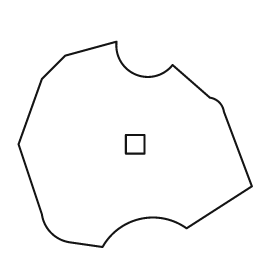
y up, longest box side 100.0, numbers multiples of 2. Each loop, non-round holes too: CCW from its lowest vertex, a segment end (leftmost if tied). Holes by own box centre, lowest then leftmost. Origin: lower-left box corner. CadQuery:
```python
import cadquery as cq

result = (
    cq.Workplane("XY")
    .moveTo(36.0, 0.0)
    .threePointArc((52.0, 12.0), (72.0, 8.0))
    .lineTo(100.0, 26.0)
    .lineTo(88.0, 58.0)
    .threePointArc((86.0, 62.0), (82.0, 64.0))
    .lineTo(66.0, 78.0)
    .threePointArc((50.0, 74.0), (42.0, 88.0))
    .lineTo(20.0, 82.0)
    .lineTo(10.0, 72.0)
    .lineTo(0.0, 44.0)
    .lineTo(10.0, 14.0)
    .threePointArc((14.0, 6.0), (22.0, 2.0))
    .close()
    .moveTo(46.0, 40.0)
    .lineTo(54.0, 40.0)
    .lineTo(54.0, 48.0)
    .lineTo(46.0, 48.0)
    .close()
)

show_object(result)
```